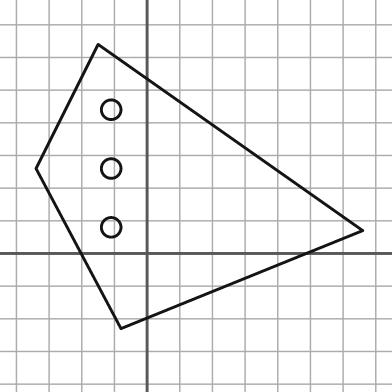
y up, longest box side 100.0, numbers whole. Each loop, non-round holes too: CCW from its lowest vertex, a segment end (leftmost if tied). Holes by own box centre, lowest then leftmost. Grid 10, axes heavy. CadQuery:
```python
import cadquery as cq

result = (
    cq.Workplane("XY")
    .moveTo(-8.0, -23.0)
    .lineTo(66.0, 7.0)
    .lineTo(-15.0, 64.0)
    .lineTo(-34.0, 26.0)
    .close()
    .moveTo(-11.0, 8.0)
    .circle(3.0)
    .moveTo(-11.0, 26.0)
    .circle(3.0)
    .moveTo(-11.0, 44.0)
    .circle(3.0)
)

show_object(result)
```